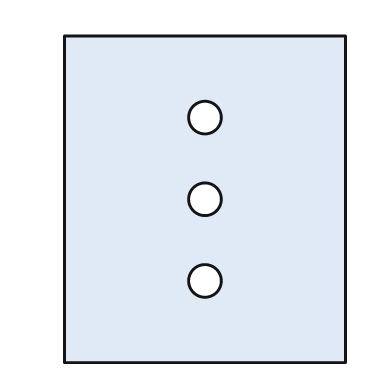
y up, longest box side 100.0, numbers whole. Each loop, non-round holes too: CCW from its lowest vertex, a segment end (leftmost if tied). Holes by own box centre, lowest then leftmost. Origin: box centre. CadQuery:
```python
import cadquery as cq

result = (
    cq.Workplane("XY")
    .moveTo(-43.0, -50.0)
    .lineTo(43.0, -50.0)
    .lineTo(43.0, 50.0)
    .lineTo(-43.0, 50.0)
    .close()
    .moveTo(0.0, -25.0)
    .circle(5.0)
    .moveTo(0.0, 0.0)
    .circle(5.0)
    .moveTo(0.0, 25.0)
    .circle(5.0)
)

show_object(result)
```